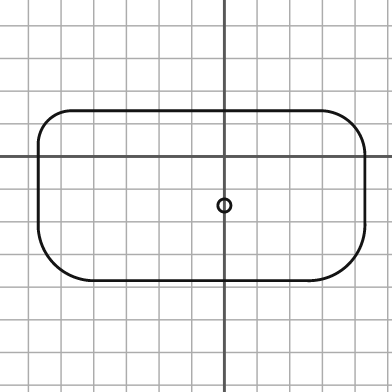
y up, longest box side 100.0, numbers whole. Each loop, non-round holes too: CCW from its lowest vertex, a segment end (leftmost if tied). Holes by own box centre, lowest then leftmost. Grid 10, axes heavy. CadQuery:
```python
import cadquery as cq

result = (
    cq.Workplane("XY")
    .moveTo(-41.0, -38.0)
    .lineTo(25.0, -38.0)
    .threePointArc((38.0, -33.0), (43.0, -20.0))
    .lineTo(43.0, 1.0)
    .threePointArc((39.0, 10.0), (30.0, 14.0))
    .lineTo(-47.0, 14.0)
    .threePointArc((-54.0, 11.0), (-57.0, 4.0))
    .lineTo(-57.0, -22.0)
    .threePointArc((-52.0, -33.0), (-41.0, -38.0))
    .close()
    .moveTo(0.0, -15.0)
    .circle(2.0)
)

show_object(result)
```